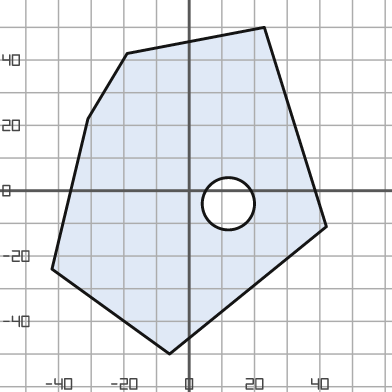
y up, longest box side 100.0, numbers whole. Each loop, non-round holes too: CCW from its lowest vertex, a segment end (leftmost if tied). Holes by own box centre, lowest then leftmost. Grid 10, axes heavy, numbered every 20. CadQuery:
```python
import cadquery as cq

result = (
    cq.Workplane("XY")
    .moveTo(-6.0, -50.0)
    .lineTo(42.0, -11.0)
    .lineTo(23.0, 50.0)
    .lineTo(-19.0, 42.0)
    .lineTo(-31.0, 22.0)
    .lineTo(-42.0, -24.0)
    .close()
    .moveTo(12.0, -4.0)
    .circle(8.0)
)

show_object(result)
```